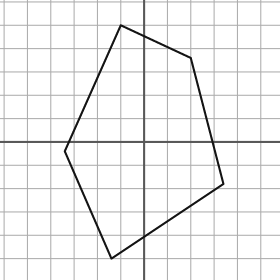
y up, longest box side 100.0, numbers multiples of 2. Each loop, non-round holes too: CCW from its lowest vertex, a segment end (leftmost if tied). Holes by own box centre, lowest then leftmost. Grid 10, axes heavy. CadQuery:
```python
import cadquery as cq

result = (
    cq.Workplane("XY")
    .moveTo(-14.0, -50.0)
    .lineTo(34.0, -18.0)
    .lineTo(20.0, 36.0)
    .lineTo(-10.0, 50.0)
    .lineTo(-34.0, -4.0)
    .close()
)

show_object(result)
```